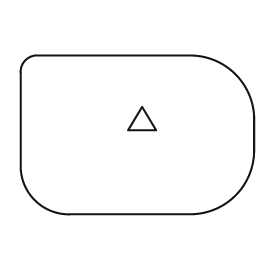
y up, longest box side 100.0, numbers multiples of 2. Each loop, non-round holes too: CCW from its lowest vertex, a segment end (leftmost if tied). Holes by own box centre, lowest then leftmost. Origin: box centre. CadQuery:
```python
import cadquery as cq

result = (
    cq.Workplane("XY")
    .moveTo(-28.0, -34.0)
    .lineTo(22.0, -34.0)
    .threePointArc((42.0, -26.0), (50.0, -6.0))
    .lineTo(50.0, 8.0)
    .threePointArc((42.0, 26.0), (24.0, 34.0))
    .lineTo(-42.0, 34.0)
    .threePointArc((-48.0, 32.0), (-50.0, 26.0))
    .lineTo(-50.0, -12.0)
    .threePointArc((-44.0, -28.0), (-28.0, -34.0))
    .close()
    .moveTo(-4.0, 2.0)
    .lineTo(8.0, 2.0)
    .lineTo(2.0, 12.0)
    .close()
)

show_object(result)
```